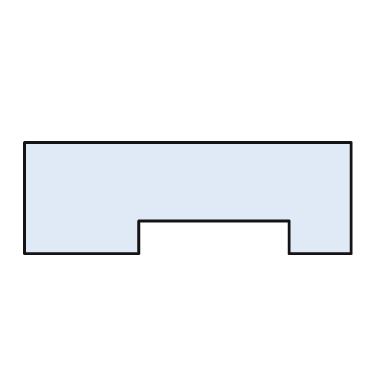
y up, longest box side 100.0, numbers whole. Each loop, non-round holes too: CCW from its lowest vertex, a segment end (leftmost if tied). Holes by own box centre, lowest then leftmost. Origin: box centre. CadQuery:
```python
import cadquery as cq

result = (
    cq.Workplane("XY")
    .moveTo(-50.0, -17.0)
    .lineTo(-15.0, -17.0)
    .lineTo(-15.0, -7.0)
    .lineTo(31.0, -7.0)
    .lineTo(31.0, -17.0)
    .lineTo(50.0, -17.0)
    .lineTo(50.0, 17.0)
    .lineTo(-50.0, 17.0)
    .close()
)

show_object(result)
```